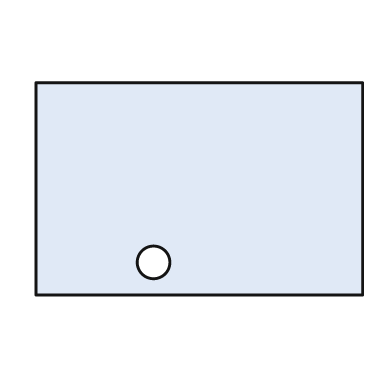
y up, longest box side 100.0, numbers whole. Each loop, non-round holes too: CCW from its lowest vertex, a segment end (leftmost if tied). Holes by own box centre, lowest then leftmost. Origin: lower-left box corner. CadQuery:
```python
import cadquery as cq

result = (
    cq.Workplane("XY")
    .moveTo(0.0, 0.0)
    .lineTo(100.0, 0.0)
    .lineTo(100.0, 65.0)
    .lineTo(0.0, 65.0)
    .close()
    .moveTo(36.0, 10.0)
    .circle(5.0)
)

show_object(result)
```